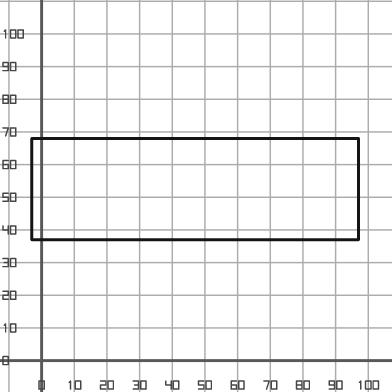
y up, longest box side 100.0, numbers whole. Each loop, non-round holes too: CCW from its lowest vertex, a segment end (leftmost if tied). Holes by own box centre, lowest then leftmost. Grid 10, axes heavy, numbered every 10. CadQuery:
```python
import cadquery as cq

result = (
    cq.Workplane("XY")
    .moveTo(-3.0, 37.0)
    .lineTo(97.0, 37.0)
    .lineTo(97.0, 68.0)
    .lineTo(-3.0, 68.0)
    .close()
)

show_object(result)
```